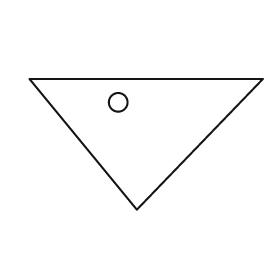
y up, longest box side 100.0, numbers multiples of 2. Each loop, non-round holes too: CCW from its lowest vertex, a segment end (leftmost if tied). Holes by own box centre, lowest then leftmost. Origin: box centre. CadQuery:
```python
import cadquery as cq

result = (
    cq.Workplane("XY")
    .moveTo(-4.0, -28.0)
    .lineTo(50.0, 28.0)
    .lineTo(-50.0, 28.0)
    .close()
    .moveTo(-12.0, 18.0)
    .circle(4.0)
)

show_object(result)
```